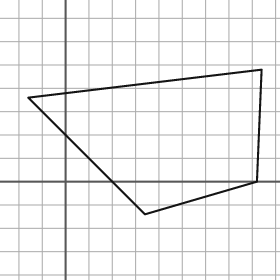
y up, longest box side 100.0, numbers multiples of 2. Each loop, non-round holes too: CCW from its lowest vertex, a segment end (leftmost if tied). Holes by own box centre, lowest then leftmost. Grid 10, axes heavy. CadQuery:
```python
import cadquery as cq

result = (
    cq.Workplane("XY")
    .moveTo(34.0, -14.0)
    .lineTo(82.0, 0.0)
    .lineTo(84.0, 48.0)
    .lineTo(-16.0, 36.0)
    .close()
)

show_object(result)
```